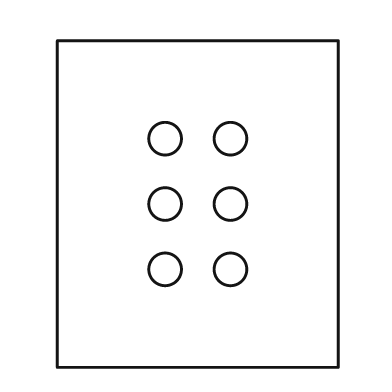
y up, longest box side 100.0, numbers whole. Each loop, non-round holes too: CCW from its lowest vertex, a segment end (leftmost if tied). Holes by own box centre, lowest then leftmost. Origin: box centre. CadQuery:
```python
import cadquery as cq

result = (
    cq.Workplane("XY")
    .moveTo(-43.0, -50.0)
    .lineTo(43.0, -50.0)
    .lineTo(43.0, 50.0)
    .lineTo(-43.0, 50.0)
    .close()
    .moveTo(-10.0, -20.0)
    .circle(5.0)
    .moveTo(10.0, -20.0)
    .circle(5.0)
    .moveTo(-10.0, 0.0)
    .circle(5.0)
    .moveTo(10.0, 0.0)
    .circle(5.0)
    .moveTo(-10.0, 20.0)
    .circle(5.0)
    .moveTo(10.0, 20.0)
    .circle(5.0)
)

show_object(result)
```